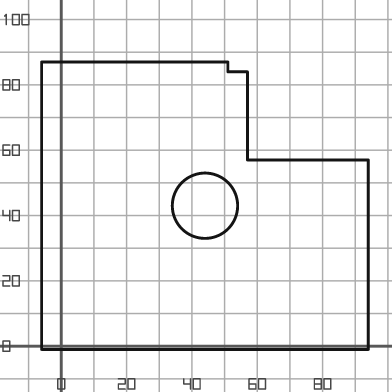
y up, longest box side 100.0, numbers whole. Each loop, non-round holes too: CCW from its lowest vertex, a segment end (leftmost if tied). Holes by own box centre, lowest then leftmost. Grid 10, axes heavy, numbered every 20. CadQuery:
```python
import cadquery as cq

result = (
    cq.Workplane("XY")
    .moveTo(-6.0, -1.0)
    .lineTo(94.0, -1.0)
    .lineTo(94.0, 57.0)
    .lineTo(57.0, 57.0)
    .lineTo(57.0, 84.0)
    .lineTo(51.0, 84.0)
    .lineTo(51.0, 87.0)
    .lineTo(-6.0, 87.0)
    .close()
    .moveTo(44.0, 43.0)
    .circle(10.0)
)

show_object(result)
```